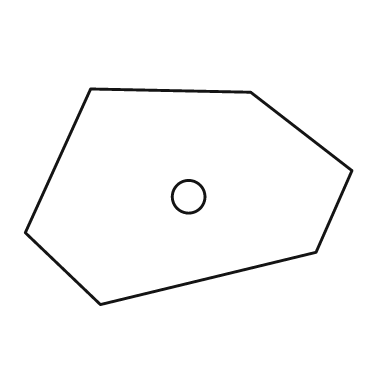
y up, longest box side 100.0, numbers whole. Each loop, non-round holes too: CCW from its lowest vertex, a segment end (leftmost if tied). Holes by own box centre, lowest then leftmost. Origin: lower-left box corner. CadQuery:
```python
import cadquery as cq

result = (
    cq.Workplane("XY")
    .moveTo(23.0, 0.0)
    .lineTo(89.0, 16.0)
    .lineTo(100.0, 41.0)
    .lineTo(69.0, 65.0)
    .lineTo(20.0, 66.0)
    .lineTo(0.0, 22.0)
    .close()
    .moveTo(50.0, 33.0)
    .circle(5.0)
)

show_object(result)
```